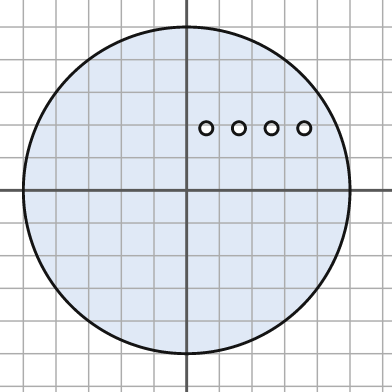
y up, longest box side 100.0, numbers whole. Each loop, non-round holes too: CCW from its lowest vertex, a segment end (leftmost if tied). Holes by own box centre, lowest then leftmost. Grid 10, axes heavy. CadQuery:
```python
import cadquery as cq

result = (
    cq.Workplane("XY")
    .moveTo(0.0, 0.0)
    .circle(50.0)
    .moveTo(6.0, 19.0)
    .circle(2.0)
    .moveTo(16.0, 19.0)
    .circle(2.0)
    .moveTo(26.0, 19.0)
    .circle(2.0)
    .moveTo(36.0, 19.0)
    .circle(2.0)
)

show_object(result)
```